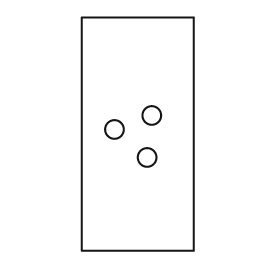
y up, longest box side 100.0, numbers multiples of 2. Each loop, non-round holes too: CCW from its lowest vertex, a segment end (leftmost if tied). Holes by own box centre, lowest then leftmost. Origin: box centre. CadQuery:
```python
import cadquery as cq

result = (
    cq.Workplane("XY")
    .moveTo(-24.0, -50.0)
    .lineTo(24.0, -50.0)
    .lineTo(24.0, 50.0)
    .lineTo(-24.0, 50.0)
    .close()
    .moveTo(4.0, -10.0)
    .circle(4.0)
    .moveTo(-10.0, 2.0)
    .circle(4.0)
    .moveTo(6.0, 8.0)
    .circle(4.0)
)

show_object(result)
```